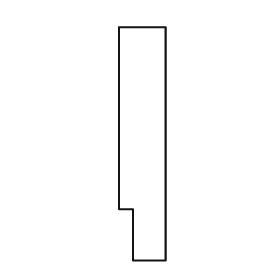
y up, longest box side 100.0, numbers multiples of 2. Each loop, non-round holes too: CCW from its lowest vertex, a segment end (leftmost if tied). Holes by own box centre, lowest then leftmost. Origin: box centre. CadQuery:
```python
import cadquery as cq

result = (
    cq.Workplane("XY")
    .moveTo(-4.0, -50.0)
    .lineTo(10.0, -50.0)
    .lineTo(10.0, 50.0)
    .lineTo(-10.0, 50.0)
    .lineTo(-10.0, -28.0)
    .lineTo(-4.0, -28.0)
    .close()
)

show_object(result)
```